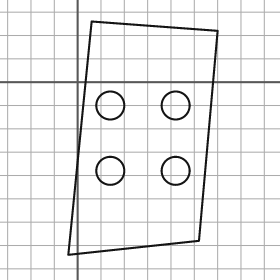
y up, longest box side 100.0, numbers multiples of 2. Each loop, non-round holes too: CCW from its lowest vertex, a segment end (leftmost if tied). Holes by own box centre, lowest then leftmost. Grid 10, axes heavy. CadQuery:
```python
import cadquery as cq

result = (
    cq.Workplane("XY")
    .moveTo(-4.0, -74.0)
    .lineTo(52.0, -68.0)
    .lineTo(60.0, 22.0)
    .lineTo(6.0, 26.0)
    .close()
    .moveTo(14.0, -38.0)
    .circle(6.0)
    .moveTo(42.0, -38.0)
    .circle(6.0)
    .moveTo(14.0, -10.0)
    .circle(6.0)
    .moveTo(42.0, -10.0)
    .circle(6.0)
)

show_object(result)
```